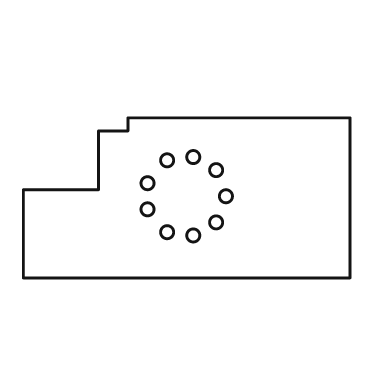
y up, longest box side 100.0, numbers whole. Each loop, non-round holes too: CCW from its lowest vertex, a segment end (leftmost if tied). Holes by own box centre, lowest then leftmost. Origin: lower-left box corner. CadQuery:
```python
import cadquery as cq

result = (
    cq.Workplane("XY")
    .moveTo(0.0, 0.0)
    .lineTo(100.0, 0.0)
    .lineTo(100.0, 49.0)
    .lineTo(32.0, 49.0)
    .lineTo(32.0, 45.0)
    .lineTo(23.0, 45.0)
    .lineTo(23.0, 27.0)
    .lineTo(0.0, 27.0)
    .close()
    .moveTo(52.0, 13.0)
    .circle(2.0)
    .moveTo(44.0, 14.0)
    .circle(2.0)
    .moveTo(59.0, 17.0)
    .circle(2.0)
    .moveTo(38.0, 21.0)
    .circle(2.0)
    .moveTo(62.0, 25.0)
    .circle(2.0)
    .moveTo(38.0, 29.0)
    .circle(2.0)
    .moveTo(59.0, 33.0)
    .circle(2.0)
    .moveTo(44.0, 36.0)
    .circle(2.0)
    .moveTo(52.0, 37.0)
    .circle(2.0)
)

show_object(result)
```